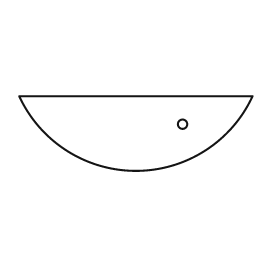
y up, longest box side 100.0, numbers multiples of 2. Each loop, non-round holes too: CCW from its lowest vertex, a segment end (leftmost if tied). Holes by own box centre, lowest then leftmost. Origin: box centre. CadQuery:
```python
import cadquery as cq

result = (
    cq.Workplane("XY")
    .moveTo(-50.0, 16.0)
    .threePointArc((0.0, -16.0), (50.0, 16.0))
    .close()
    .moveTo(20.0, 4.0)
    .circle(2.0)
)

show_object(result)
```